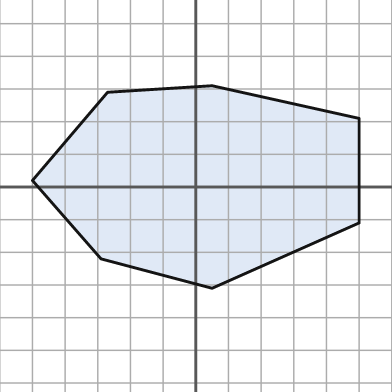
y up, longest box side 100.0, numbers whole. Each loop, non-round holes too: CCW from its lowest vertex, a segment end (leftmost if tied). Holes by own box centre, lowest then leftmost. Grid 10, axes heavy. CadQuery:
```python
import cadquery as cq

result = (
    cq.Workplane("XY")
    .moveTo(5.0, -31.0)
    .lineTo(50.0, -11.0)
    .lineTo(50.0, 21.0)
    .lineTo(5.0, 31.0)
    .lineTo(-27.0, 29.0)
    .lineTo(-50.0, 2.0)
    .lineTo(-29.0, -22.0)
    .close()
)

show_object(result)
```